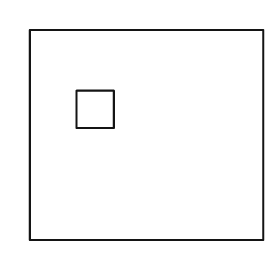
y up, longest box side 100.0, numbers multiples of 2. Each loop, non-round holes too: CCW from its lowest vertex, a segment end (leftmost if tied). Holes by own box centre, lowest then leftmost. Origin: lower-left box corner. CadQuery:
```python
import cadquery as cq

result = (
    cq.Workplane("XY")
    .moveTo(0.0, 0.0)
    .lineTo(100.0, 0.0)
    .lineTo(100.0, 90.0)
    .lineTo(0.0, 90.0)
    .close()
    .moveTo(20.0, 48.0)
    .lineTo(36.0, 48.0)
    .lineTo(36.0, 64.0)
    .lineTo(20.0, 64.0)
    .close()
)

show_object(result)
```